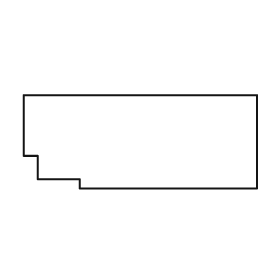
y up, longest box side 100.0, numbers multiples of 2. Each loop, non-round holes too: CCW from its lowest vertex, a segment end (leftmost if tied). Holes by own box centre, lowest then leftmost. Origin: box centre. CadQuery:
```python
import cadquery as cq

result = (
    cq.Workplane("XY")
    .moveTo(-26.0, -20.0)
    .lineTo(50.0, -20.0)
    .lineTo(50.0, 20.0)
    .lineTo(-50.0, 20.0)
    .lineTo(-50.0, -6.0)
    .lineTo(-44.0, -6.0)
    .lineTo(-44.0, -16.0)
    .lineTo(-26.0, -16.0)
    .close()
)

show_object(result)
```